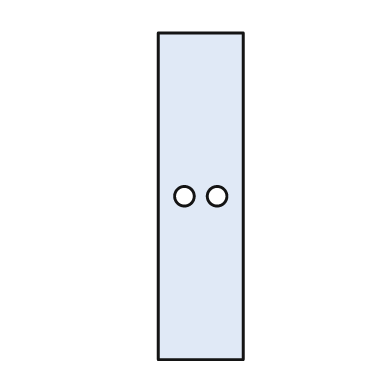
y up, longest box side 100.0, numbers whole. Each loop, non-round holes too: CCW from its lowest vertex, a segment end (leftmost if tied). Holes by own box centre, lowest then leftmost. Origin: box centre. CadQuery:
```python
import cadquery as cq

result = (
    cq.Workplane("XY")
    .moveTo(-13.0, -50.0)
    .lineTo(13.0, -50.0)
    .lineTo(13.0, 50.0)
    .lineTo(-13.0, 50.0)
    .close()
    .moveTo(-5.0, 0.0)
    .circle(3.0)
    .moveTo(5.0, 0.0)
    .circle(3.0)
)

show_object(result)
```